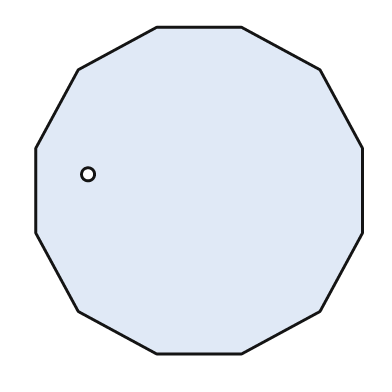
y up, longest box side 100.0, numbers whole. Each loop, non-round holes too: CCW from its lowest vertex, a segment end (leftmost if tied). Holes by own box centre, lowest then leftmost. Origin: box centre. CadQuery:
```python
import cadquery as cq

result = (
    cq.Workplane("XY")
    .moveTo(-13.0, -50.0)
    .lineTo(13.0, -50.0)
    .lineTo(37.0, -37.0)
    .lineTo(50.0, -13.0)
    .lineTo(50.0, 13.0)
    .lineTo(37.0, 37.0)
    .lineTo(13.0, 50.0)
    .lineTo(-13.0, 50.0)
    .lineTo(-37.0, 37.0)
    .lineTo(-50.0, 13.0)
    .lineTo(-50.0, -13.0)
    .lineTo(-37.0, -37.0)
    .close()
    .moveTo(-34.0, 5.0)
    .circle(2.0)
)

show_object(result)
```